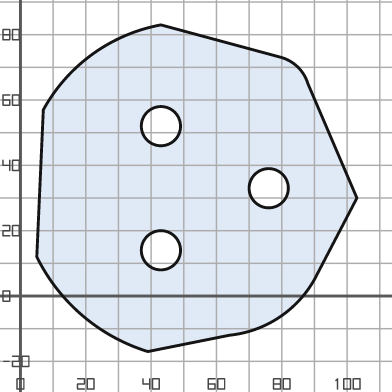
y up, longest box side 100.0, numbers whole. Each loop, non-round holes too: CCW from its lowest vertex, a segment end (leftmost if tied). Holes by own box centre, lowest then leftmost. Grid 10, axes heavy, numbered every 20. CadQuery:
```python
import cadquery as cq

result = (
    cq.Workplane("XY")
    .moveTo(39.0, -17.0)
    .lineTo(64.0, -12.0)
    .threePointArc((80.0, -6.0), (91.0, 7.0))
    .lineTo(103.0, 30.0)
    .lineTo(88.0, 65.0)
    .threePointArc((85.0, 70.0), (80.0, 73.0))
    .lineTo(43.0, 83.0)
    .threePointArc((22.0, 74.0), (7.0, 57.0))
    .lineTo(5.0, 12.0)
    .threePointArc((19.0, -6.0), (39.0, -17.0))
    .close()
    .moveTo(43.0, 14.0)
    .circle(6.0)
    .moveTo(76.0, 33.0)
    .circle(6.0)
    .moveTo(43.0, 52.0)
    .circle(6.0)
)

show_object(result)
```